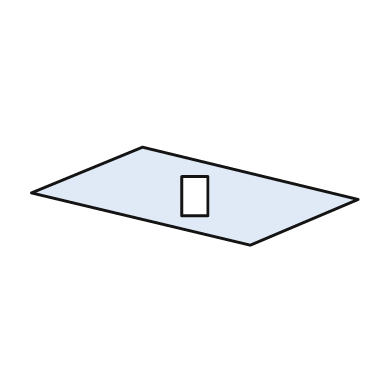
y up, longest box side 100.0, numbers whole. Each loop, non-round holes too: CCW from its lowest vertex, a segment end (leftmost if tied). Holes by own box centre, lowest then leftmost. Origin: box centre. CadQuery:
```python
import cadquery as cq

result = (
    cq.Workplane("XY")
    .moveTo(17.0, -15.0)
    .lineTo(50.0, -1.0)
    .lineTo(-16.0, 15.0)
    .lineTo(-50.0, 1.0)
    .close()
    .moveTo(-4.0, -6.0)
    .lineTo(4.0, -6.0)
    .lineTo(4.0, 6.0)
    .lineTo(-4.0, 6.0)
    .close()
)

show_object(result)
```